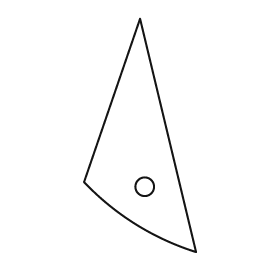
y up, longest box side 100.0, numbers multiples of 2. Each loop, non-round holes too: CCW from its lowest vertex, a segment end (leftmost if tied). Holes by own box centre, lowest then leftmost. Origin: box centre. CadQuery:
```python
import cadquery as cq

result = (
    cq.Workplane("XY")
    .moveTo(24.0, -50.0)
    .lineTo(0.0, 50.0)
    .lineTo(-24.0, -20.0)
    .threePointArc((-2.0, -38.0), (24.0, -50.0))
    .close()
    .moveTo(2.0, -22.0)
    .circle(4.0)
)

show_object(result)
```